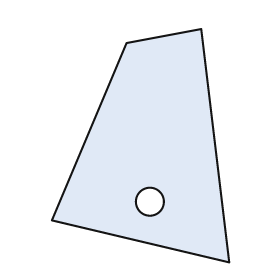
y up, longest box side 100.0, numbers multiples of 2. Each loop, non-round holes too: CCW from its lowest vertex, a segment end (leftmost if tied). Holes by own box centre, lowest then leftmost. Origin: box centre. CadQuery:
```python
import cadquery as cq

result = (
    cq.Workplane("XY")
    .moveTo(38.0, -50.0)
    .lineTo(26.0, 50.0)
    .lineTo(-6.0, 44.0)
    .lineTo(-38.0, -32.0)
    .close()
    .moveTo(4.0, -24.0)
    .circle(6.0)
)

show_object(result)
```